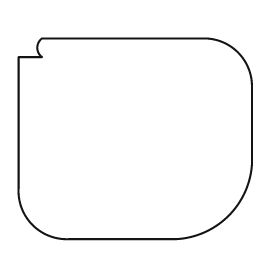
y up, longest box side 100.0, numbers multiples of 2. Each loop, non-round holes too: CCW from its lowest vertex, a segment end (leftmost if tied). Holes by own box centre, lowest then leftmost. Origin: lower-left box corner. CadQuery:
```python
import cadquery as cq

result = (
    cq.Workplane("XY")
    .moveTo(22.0, 0.0)
    .lineTo(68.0, 0.0)
    .threePointArc((90.0, 10.0), (100.0, 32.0))
    .lineTo(100.0, 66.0)
    .threePointArc((94.0, 80.0), (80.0, 86.0))
    .lineTo(10.0, 86.0)
    .threePointArc((8.0, 82.0), (10.0, 78.0))
    .lineTo(0.0, 78.0)
    .lineTo(0.0, 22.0)
    .threePointArc((6.0, 6.0), (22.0, 0.0))
    .close()
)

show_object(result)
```